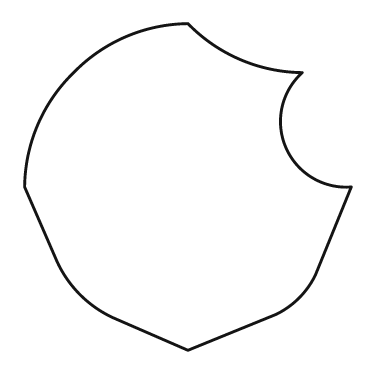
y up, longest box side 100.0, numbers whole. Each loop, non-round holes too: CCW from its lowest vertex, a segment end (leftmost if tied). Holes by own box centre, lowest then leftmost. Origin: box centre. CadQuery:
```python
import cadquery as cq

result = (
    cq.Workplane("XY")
    .moveTo(0.0, -50.0)
    .lineTo(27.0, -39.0)
    .threePointArc((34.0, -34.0), (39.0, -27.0))
    .lineTo(50.0, 0.0)
    .threePointArc((30.0, 12.0), (35.0, 35.0))
    .threePointArc((16.0, 39.0), (0.0, 50.0))
    .threePointArc((-19.0, 46.0), (-35.0, 35.0))
    .threePointArc((-46.0, 19.0), (-50.0, 0.0))
    .lineTo(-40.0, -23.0)
    .threePointArc((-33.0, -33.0), (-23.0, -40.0))
    .close()
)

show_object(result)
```